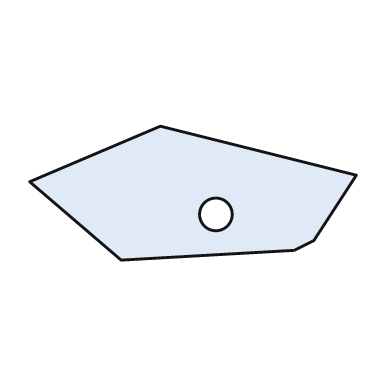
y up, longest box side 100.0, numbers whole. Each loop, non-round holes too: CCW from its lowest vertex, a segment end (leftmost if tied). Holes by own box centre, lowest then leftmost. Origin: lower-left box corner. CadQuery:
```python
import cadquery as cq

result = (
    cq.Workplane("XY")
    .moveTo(28.0, 0.0)
    .lineTo(81.0, 3.0)
    .lineTo(87.0, 6.0)
    .lineTo(100.0, 26.0)
    .lineTo(40.0, 41.0)
    .lineTo(0.0, 24.0)
    .close()
    .moveTo(57.0, 14.0)
    .circle(5.0)
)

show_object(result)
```